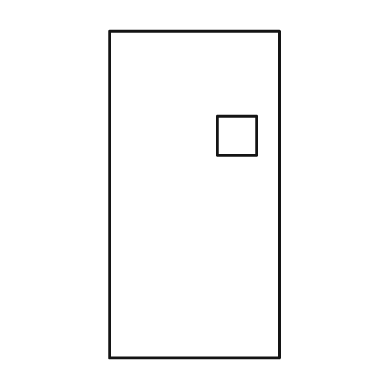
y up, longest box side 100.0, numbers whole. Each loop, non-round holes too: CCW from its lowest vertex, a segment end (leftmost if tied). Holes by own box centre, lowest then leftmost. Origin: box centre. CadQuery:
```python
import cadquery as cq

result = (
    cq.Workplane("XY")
    .moveTo(-26.0, -50.0)
    .lineTo(26.0, -50.0)
    .lineTo(26.0, 50.0)
    .lineTo(-26.0, 50.0)
    .close()
    .moveTo(7.0, 12.0)
    .lineTo(19.0, 12.0)
    .lineTo(19.0, 24.0)
    .lineTo(7.0, 24.0)
    .close()
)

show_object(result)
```